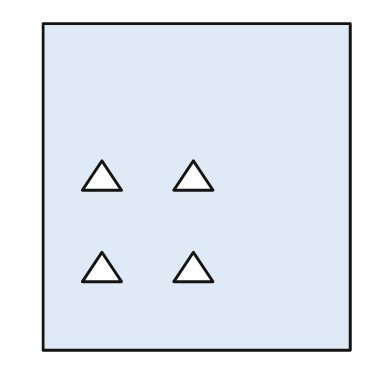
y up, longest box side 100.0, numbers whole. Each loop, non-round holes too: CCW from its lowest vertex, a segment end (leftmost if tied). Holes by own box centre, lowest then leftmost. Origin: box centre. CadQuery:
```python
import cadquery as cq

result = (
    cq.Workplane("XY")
    .moveTo(-47.0, -50.0)
    .lineTo(47.0, -50.0)
    .lineTo(47.0, 50.0)
    .lineTo(-47.0, 50.0)
    .close()
    .moveTo(-35.0, -29.0)
    .lineTo(-23.0, -29.0)
    .lineTo(-29.0, -20.0)
    .close()
    .moveTo(-7.0, -29.0)
    .lineTo(5.0, -29.0)
    .lineTo(-1.0, -20.0)
    .close()
    .moveTo(-35.0, -1.0)
    .lineTo(-23.0, -1.0)
    .lineTo(-29.0, 8.0)
    .close()
    .moveTo(-7.0, -1.0)
    .lineTo(5.0, -1.0)
    .lineTo(-1.0, 8.0)
    .close()
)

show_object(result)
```